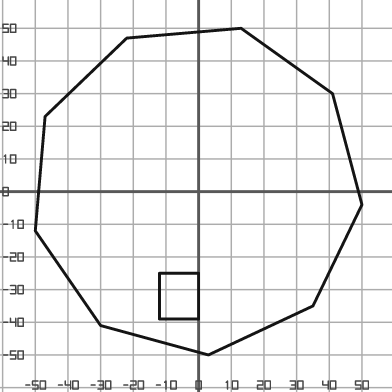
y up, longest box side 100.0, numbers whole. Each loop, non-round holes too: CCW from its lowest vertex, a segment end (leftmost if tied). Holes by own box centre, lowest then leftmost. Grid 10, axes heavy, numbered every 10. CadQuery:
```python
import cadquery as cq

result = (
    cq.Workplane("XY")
    .moveTo(3.0, -50.0)
    .lineTo(35.0, -35.0)
    .lineTo(50.0, -4.0)
    .lineTo(41.0, 30.0)
    .lineTo(13.0, 50.0)
    .lineTo(-22.0, 47.0)
    .lineTo(-47.0, 23.0)
    .lineTo(-50.0, -12.0)
    .lineTo(-30.0, -41.0)
    .close()
    .moveTo(-12.0, -39.0)
    .lineTo(0.0, -39.0)
    .lineTo(0.0, -25.0)
    .lineTo(-12.0, -25.0)
    .close()
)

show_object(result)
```